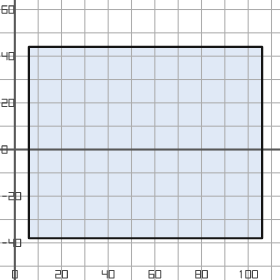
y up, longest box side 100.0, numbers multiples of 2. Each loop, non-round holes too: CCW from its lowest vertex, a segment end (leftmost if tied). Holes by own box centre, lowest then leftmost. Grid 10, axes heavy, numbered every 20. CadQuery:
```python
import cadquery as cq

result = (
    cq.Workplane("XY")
    .moveTo(6.0, -38.0)
    .lineTo(106.0, -38.0)
    .lineTo(106.0, 44.0)
    .lineTo(6.0, 44.0)
    .close()
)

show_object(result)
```